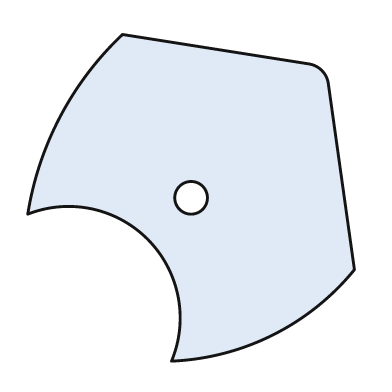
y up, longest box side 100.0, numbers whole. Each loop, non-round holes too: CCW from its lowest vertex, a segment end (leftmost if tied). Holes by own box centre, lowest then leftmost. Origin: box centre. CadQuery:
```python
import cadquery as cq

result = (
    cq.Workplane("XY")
    .moveTo(-6.0, -50.0)
    .threePointArc((25.0, -42.0), (50.0, -22.0))
    .lineTo(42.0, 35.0)
    .threePointArc((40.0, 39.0), (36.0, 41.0))
    .lineTo(-21.0, 50.0)
    .threePointArc((-40.0, 25.0), (-50.0, -5.0))
    .threePointArc((-13.0, -13.0), (-6.0, -50.0))
    .close()
    .moveTo(0.0, 0.0)
    .circle(5.0)
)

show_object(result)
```